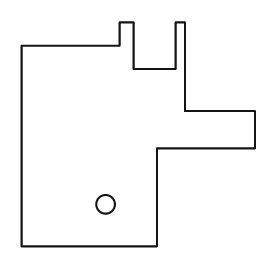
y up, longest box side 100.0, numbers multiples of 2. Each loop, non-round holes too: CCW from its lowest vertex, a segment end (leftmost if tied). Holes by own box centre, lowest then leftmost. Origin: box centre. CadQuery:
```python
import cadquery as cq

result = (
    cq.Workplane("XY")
    .moveTo(-50.0, -48.0)
    .lineTo(8.0, -48.0)
    .lineTo(8.0, -6.0)
    .lineTo(50.0, -6.0)
    .lineTo(50.0, 10.0)
    .lineTo(20.0, 10.0)
    .lineTo(20.0, 48.0)
    .lineTo(16.0, 48.0)
    .lineTo(16.0, 28.0)
    .lineTo(-2.0, 28.0)
    .lineTo(-2.0, 48.0)
    .lineTo(-8.0, 48.0)
    .lineTo(-8.0, 38.0)
    .lineTo(-50.0, 38.0)
    .close()
    .moveTo(-14.0, -30.0)
    .circle(4.0)
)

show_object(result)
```